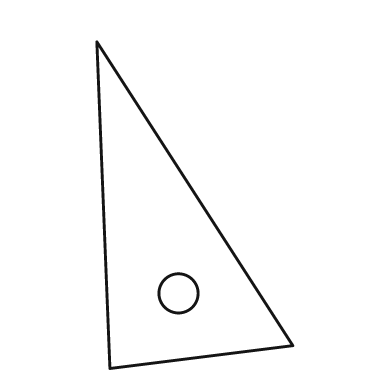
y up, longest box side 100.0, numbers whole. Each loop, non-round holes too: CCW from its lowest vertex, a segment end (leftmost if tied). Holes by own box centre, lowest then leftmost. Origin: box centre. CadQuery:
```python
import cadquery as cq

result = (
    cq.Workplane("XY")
    .moveTo(-26.0, -50.0)
    .lineTo(30.0, -43.0)
    .lineTo(-30.0, 50.0)
    .close()
    .moveTo(-5.0, -27.0)
    .circle(6.0)
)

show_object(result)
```